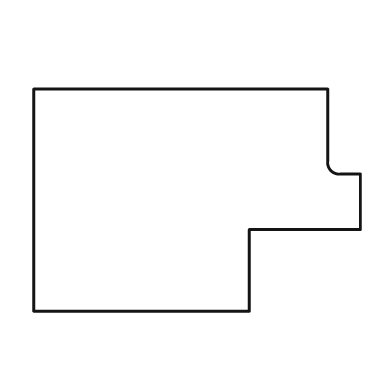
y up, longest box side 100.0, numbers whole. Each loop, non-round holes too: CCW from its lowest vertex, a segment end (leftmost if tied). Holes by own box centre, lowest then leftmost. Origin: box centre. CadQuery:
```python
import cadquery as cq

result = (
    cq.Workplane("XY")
    .moveTo(-50.0, -34.0)
    .lineTo(16.0, -34.0)
    .lineTo(16.0, -9.0)
    .lineTo(50.0, -9.0)
    .lineTo(50.0, 8.0)
    .lineTo(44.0, 8.0)
    .threePointArc((41.0, 9.0), (40.0, 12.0))
    .lineTo(40.0, 34.0)
    .lineTo(-50.0, 34.0)
    .close()
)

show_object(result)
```